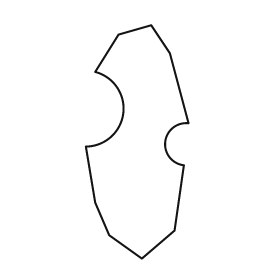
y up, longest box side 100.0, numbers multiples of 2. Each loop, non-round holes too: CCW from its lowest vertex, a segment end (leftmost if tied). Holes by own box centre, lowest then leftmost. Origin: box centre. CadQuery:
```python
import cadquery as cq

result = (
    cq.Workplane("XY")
    .moveTo(2.0, -50.0)
    .lineTo(16.0, -38.0)
    .lineTo(20.0, -10.0)
    .threePointArc((12.0, 0.0), (22.0, 8.0))
    .lineTo(14.0, 38.0)
    .lineTo(6.0, 50.0)
    .lineTo(-8.0, 46.0)
    .lineTo(-18.0, 30.0)
    .threePointArc((-6.0, 12.0), (-22.0, -2.0))
    .lineTo(-18.0, -26.0)
    .lineTo(-12.0, -40.0)
    .close()
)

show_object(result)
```